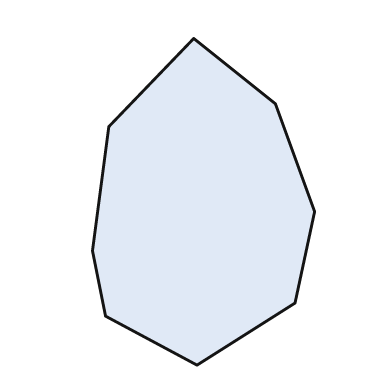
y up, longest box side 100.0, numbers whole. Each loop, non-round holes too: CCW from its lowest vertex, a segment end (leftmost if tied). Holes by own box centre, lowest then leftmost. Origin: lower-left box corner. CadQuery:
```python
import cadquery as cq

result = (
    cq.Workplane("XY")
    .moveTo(32.0, 0.0)
    .lineTo(62.0, 19.0)
    .lineTo(68.0, 47.0)
    .lineTo(56.0, 80.0)
    .lineTo(31.0, 100.0)
    .lineTo(5.0, 73.0)
    .lineTo(0.0, 35.0)
    .lineTo(4.0, 15.0)
    .close()
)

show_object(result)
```